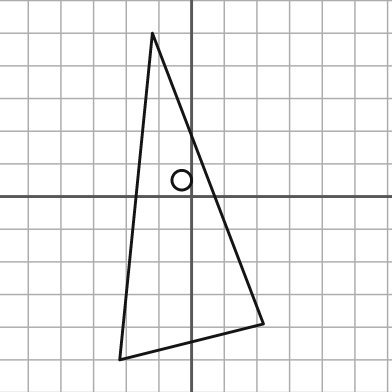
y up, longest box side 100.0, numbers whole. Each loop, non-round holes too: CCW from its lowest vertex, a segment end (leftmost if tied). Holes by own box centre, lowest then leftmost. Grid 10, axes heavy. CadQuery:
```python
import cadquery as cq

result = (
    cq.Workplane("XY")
    .moveTo(-22.0, -50.0)
    .lineTo(22.0, -39.0)
    .lineTo(-12.0, 50.0)
    .close()
    .moveTo(-3.0, 5.0)
    .circle(3.0)
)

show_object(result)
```